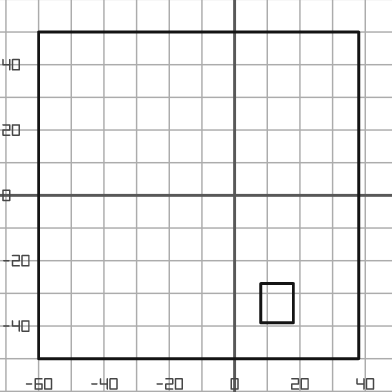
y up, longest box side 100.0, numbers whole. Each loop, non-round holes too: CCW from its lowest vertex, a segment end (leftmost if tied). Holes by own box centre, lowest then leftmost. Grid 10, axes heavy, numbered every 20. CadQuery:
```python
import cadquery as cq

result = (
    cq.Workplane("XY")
    .moveTo(-60.0, -50.0)
    .lineTo(38.0, -50.0)
    .lineTo(38.0, 50.0)
    .lineTo(-60.0, 50.0)
    .close()
    .moveTo(8.0, -39.0)
    .lineTo(18.0, -39.0)
    .lineTo(18.0, -27.0)
    .lineTo(8.0, -27.0)
    .close()
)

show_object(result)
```